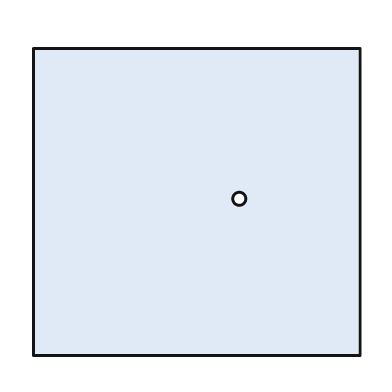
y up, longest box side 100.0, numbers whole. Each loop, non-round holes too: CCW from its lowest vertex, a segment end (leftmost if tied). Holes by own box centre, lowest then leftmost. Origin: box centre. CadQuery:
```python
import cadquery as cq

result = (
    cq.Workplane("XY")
    .moveTo(-50.0, -47.0)
    .lineTo(50.0, -47.0)
    .lineTo(50.0, 47.0)
    .lineTo(-50.0, 47.0)
    .close()
    .moveTo(13.0, 1.0)
    .circle(2.0)
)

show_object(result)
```